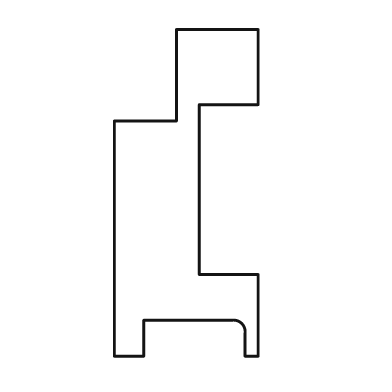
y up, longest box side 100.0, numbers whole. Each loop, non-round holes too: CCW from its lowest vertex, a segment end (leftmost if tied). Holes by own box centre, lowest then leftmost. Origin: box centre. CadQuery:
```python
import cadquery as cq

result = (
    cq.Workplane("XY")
    .moveTo(-22.0, -50.0)
    .lineTo(-13.0, -50.0)
    .lineTo(-13.0, -39.0)
    .lineTo(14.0, -39.0)
    .threePointArc((17.0, -40.0), (18.0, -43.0))
    .lineTo(18.0, -50.0)
    .lineTo(22.0, -50.0)
    .lineTo(22.0, -25.0)
    .lineTo(4.0, -25.0)
    .lineTo(4.0, 27.0)
    .lineTo(22.0, 27.0)
    .lineTo(22.0, 50.0)
    .lineTo(-3.0, 50.0)
    .lineTo(-3.0, 22.0)
    .lineTo(-22.0, 22.0)
    .close()
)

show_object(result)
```